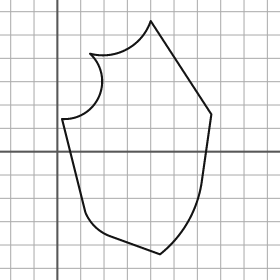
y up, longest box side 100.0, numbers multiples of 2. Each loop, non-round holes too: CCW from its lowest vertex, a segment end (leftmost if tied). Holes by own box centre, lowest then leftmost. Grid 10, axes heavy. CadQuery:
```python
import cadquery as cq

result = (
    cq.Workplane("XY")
    .moveTo(44.0, -44.0)
    .threePointArc((56.0, -30.0), (62.0, -12.0))
    .lineTo(66.0, 16.0)
    .lineTo(40.0, 56.0)
    .threePointArc((30.0, 44.0), (14.0, 42.0))
    .threePointArc((18.0, 24.0), (2.0, 14.0))
    .lineTo(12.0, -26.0)
    .threePointArc((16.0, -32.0), (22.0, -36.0))
    .close()
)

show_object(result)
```